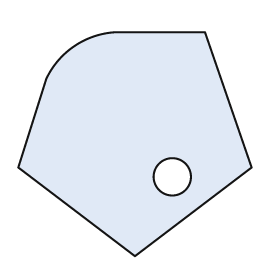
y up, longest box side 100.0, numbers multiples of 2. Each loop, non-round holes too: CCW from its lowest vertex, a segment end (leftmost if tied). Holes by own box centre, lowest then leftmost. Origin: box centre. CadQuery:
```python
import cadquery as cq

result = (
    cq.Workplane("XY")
    .moveTo(0.0, -48.0)
    .lineTo(50.0, -10.0)
    .lineTo(30.0, 48.0)
    .lineTo(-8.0, 48.0)
    .threePointArc((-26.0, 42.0), (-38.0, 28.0))
    .lineTo(-50.0, -10.0)
    .close()
    .moveTo(16.0, -14.0)
    .circle(8.0)
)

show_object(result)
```